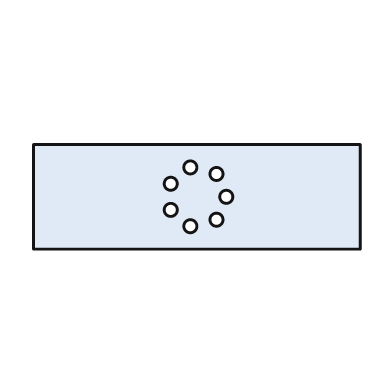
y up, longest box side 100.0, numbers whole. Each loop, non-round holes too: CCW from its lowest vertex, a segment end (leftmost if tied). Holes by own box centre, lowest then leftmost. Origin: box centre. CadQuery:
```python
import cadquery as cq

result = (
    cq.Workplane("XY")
    .moveTo(-50.0, -16.0)
    .lineTo(50.0, -16.0)
    .lineTo(50.0, 16.0)
    .lineTo(-50.0, 16.0)
    .close()
    .moveTo(-2.0, -9.0)
    .circle(2.0)
    .moveTo(6.0, -7.0)
    .circle(2.0)
    .moveTo(-8.0, -4.0)
    .circle(2.0)
    .moveTo(9.0, 0.0)
    .circle(2.0)
    .moveTo(-8.0, 4.0)
    .circle(2.0)
    .moveTo(6.0, 7.0)
    .circle(2.0)
    .moveTo(-2.0, 9.0)
    .circle(2.0)
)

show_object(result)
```